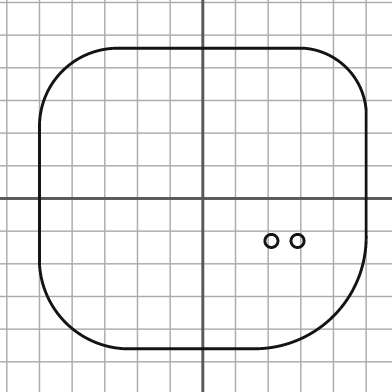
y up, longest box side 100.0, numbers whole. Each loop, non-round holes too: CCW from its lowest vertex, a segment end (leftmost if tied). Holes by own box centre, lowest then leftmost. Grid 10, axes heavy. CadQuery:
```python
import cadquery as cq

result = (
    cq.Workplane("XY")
    .moveTo(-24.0, -46.0)
    .lineTo(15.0, -46.0)
    .threePointArc((40.0, -36.0), (50.0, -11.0))
    .lineTo(50.0, 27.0)
    .threePointArc((44.0, 40.0), (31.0, 46.0))
    .lineTo(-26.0, 46.0)
    .threePointArc((-43.0, 39.0), (-50.0, 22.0))
    .lineTo(-50.0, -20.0)
    .threePointArc((-42.0, -38.0), (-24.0, -46.0))
    .close()
    .moveTo(21.0, -13.0)
    .circle(2.0)
    .moveTo(29.0, -13.0)
    .circle(2.0)
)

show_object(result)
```